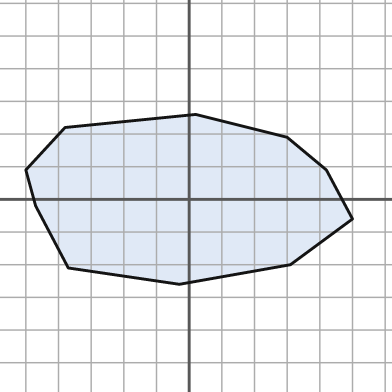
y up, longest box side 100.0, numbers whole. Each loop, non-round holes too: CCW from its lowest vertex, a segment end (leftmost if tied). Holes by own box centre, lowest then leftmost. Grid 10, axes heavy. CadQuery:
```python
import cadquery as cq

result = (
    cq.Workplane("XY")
    .moveTo(-3.0, -26.0)
    .lineTo(31.0, -20.0)
    .lineTo(50.0, -6.0)
    .lineTo(42.0, 9.0)
    .lineTo(30.0, 19.0)
    .lineTo(2.0, 26.0)
    .lineTo(-38.0, 22.0)
    .lineTo(-50.0, 9.0)
    .lineTo(-47.0, -2.0)
    .lineTo(-37.0, -21.0)
    .close()
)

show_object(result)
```